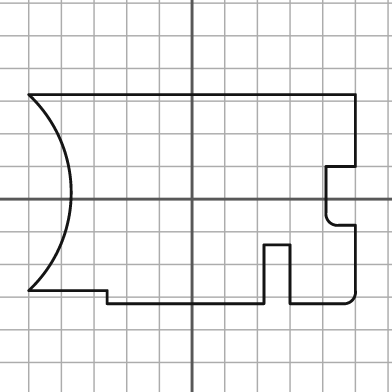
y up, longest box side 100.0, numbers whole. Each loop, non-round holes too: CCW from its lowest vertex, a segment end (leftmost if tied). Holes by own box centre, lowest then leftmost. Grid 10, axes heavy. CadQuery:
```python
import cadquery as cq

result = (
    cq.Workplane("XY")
    .moveTo(-26.0, -32.0)
    .lineTo(22.0, -32.0)
    .lineTo(22.0, -14.0)
    .lineTo(30.0, -14.0)
    .lineTo(30.0, -32.0)
    .lineTo(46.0, -32.0)
    .threePointArc((49.0, -31.0), (50.0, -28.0))
    .lineTo(50.0, -8.0)
    .lineTo(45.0, -8.0)
    .threePointArc((42.0, -7.0), (41.0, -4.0))
    .lineTo(41.0, 10.0)
    .lineTo(50.0, 10.0)
    .lineTo(50.0, 32.0)
    .lineTo(-50.0, 32.0)
    .threePointArc((-37.0, 2.0), (-50.0, -28.0))
    .lineTo(-26.0, -28.0)
    .close()
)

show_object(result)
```